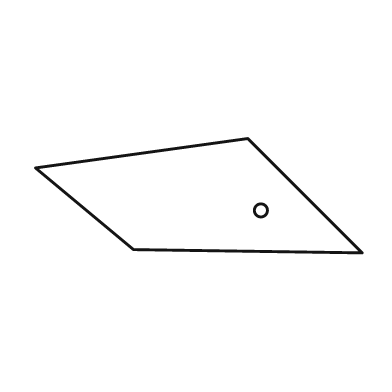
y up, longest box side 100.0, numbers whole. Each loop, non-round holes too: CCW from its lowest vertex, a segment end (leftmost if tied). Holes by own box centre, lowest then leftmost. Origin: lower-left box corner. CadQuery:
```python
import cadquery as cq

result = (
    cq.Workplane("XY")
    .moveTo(100.0, 0.0)
    .lineTo(65.0, 35.0)
    .lineTo(0.0, 26.0)
    .lineTo(30.0, 1.0)
    .close()
    .moveTo(69.0, 13.0)
    .circle(2.0)
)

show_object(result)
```